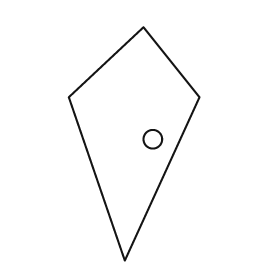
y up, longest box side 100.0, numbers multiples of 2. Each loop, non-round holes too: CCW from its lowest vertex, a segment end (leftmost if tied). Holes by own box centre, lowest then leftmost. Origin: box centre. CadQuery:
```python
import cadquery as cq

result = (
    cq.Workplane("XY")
    .moveTo(-4.0, -50.0)
    .lineTo(28.0, 20.0)
    .lineTo(4.0, 50.0)
    .lineTo(-28.0, 20.0)
    .close()
    .moveTo(8.0, 2.0)
    .circle(4.0)
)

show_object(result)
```